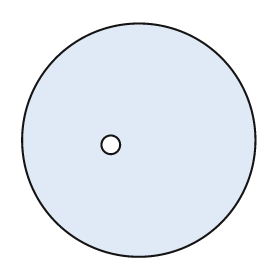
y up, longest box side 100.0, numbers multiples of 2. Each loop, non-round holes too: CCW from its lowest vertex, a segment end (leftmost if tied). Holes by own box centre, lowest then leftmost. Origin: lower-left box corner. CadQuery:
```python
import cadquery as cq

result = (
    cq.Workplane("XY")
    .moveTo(50.0, 50.0)
    .circle(50.0)
    .moveTo(38.0, 48.0)
    .circle(4.0)
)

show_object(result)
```